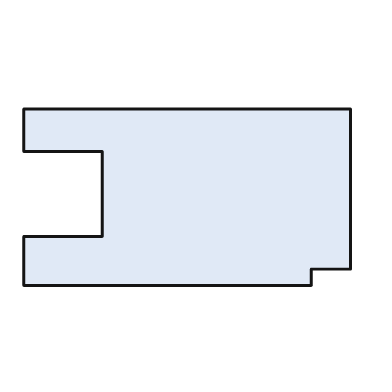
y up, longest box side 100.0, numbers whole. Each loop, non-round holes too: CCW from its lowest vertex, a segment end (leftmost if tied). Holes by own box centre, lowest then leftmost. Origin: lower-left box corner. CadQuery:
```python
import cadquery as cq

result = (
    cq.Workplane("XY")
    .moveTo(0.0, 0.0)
    .lineTo(88.0, 0.0)
    .lineTo(88.0, 5.0)
    .lineTo(100.0, 5.0)
    .lineTo(100.0, 54.0)
    .lineTo(0.0, 54.0)
    .lineTo(0.0, 41.0)
    .lineTo(24.0, 41.0)
    .lineTo(24.0, 15.0)
    .lineTo(0.0, 15.0)
    .close()
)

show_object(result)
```